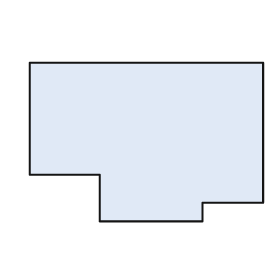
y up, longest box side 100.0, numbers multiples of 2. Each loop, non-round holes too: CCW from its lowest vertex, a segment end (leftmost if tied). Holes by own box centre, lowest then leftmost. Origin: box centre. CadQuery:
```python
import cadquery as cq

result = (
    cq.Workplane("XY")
    .moveTo(-20.0, -34.0)
    .lineTo(24.0, -34.0)
    .lineTo(24.0, -26.0)
    .lineTo(50.0, -26.0)
    .lineTo(50.0, 34.0)
    .lineTo(-50.0, 34.0)
    .lineTo(-50.0, -14.0)
    .lineTo(-20.0, -14.0)
    .close()
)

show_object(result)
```